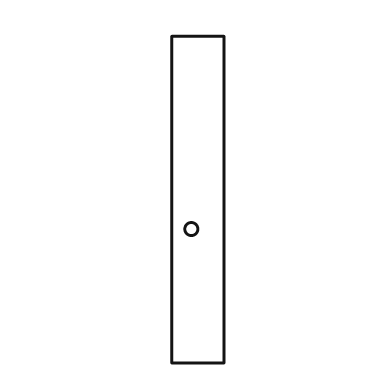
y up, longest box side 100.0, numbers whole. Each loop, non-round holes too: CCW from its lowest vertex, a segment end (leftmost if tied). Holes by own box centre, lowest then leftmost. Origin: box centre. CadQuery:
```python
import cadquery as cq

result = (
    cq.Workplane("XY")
    .moveTo(-8.0, -50.0)
    .lineTo(8.0, -50.0)
    .lineTo(8.0, 50.0)
    .lineTo(-8.0, 50.0)
    .close()
    .moveTo(-2.0, -9.0)
    .circle(2.0)
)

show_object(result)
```